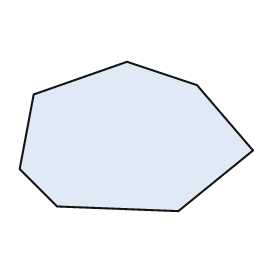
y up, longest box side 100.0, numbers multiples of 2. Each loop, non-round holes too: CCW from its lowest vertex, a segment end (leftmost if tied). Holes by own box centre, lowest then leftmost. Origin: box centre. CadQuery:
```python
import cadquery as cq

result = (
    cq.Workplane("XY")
    .moveTo(18.0, -32.0)
    .lineTo(50.0, -6.0)
    .lineTo(26.0, 22.0)
    .lineTo(-4.0, 32.0)
    .lineTo(-44.0, 18.0)
    .lineTo(-50.0, -14.0)
    .lineTo(-34.0, -30.0)
    .close()
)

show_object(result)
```